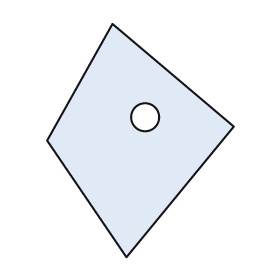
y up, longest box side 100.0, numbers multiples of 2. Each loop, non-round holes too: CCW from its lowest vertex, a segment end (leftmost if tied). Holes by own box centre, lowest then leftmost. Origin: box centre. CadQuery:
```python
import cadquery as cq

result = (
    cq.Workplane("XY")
    .moveTo(-6.0, -50.0)
    .lineTo(40.0, 6.0)
    .lineTo(-12.0, 50.0)
    .lineTo(-40.0, 0.0)
    .close()
    .moveTo(2.0, 10.0)
    .circle(6.0)
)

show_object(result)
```